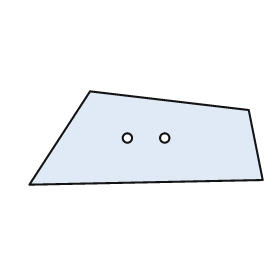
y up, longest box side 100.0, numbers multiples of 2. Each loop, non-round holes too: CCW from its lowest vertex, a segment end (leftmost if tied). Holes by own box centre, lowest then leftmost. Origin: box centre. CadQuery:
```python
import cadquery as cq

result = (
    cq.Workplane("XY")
    .moveTo(-50.0, -20.0)
    .lineTo(50.0, -18.0)
    .lineTo(44.0, 12.0)
    .lineTo(-24.0, 20.0)
    .close()
    .moveTo(-8.0, 0.0)
    .circle(2.0)
    .moveTo(8.0, 0.0)
    .circle(2.0)
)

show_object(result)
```